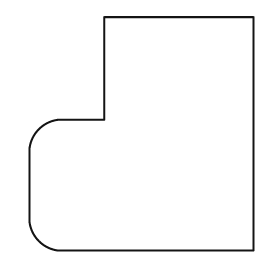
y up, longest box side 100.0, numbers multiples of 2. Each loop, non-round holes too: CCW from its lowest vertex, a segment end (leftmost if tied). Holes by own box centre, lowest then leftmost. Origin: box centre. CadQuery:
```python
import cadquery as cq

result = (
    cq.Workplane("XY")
    .moveTo(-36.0, -50.0)
    .lineTo(48.0, -50.0)
    .lineTo(48.0, 50.0)
    .lineTo(-16.0, 50.0)
    .lineTo(-16.0, 6.0)
    .lineTo(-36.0, 6.0)
    .threePointArc((-44.0, 2.0), (-48.0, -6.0))
    .lineTo(-48.0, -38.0)
    .threePointArc((-44.0, -46.0), (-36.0, -50.0))
    .close()
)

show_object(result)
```